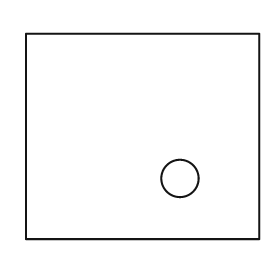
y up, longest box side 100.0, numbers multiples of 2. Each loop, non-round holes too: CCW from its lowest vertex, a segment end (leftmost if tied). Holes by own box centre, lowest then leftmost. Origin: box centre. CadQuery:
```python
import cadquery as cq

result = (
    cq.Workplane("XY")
    .moveTo(-50.0, -44.0)
    .lineTo(50.0, -44.0)
    .lineTo(50.0, 44.0)
    .lineTo(-50.0, 44.0)
    .close()
    .moveTo(16.0, -18.0)
    .circle(8.0)
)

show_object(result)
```